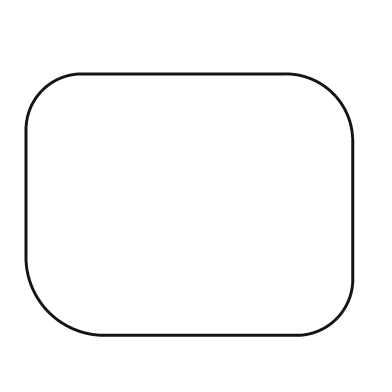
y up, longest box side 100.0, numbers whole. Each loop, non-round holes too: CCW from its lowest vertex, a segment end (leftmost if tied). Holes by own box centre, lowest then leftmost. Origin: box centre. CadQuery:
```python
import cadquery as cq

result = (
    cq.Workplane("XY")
    .moveTo(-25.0, -40.0)
    .lineTo(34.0, -40.0)
    .threePointArc((45.0, -35.0), (50.0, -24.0))
    .lineTo(50.0, 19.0)
    .threePointArc((44.0, 34.0), (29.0, 40.0))
    .lineTo(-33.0, 40.0)
    .threePointArc((-45.0, 35.0), (-50.0, 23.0))
    .lineTo(-50.0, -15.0)
    .threePointArc((-43.0, -33.0), (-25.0, -40.0))
    .close()
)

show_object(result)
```